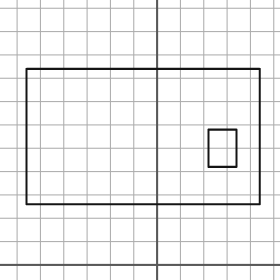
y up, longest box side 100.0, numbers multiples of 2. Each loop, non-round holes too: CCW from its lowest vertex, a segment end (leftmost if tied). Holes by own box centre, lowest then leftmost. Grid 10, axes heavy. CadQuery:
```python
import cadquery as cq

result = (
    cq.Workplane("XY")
    .moveTo(-56.0, 26.0)
    .lineTo(44.0, 26.0)
    .lineTo(44.0, 84.0)
    .lineTo(-56.0, 84.0)
    .close()
    .moveTo(22.0, 42.0)
    .lineTo(34.0, 42.0)
    .lineTo(34.0, 58.0)
    .lineTo(22.0, 58.0)
    .close()
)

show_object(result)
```